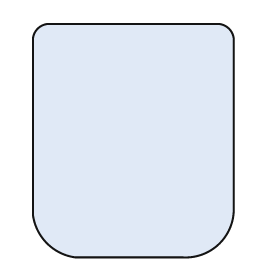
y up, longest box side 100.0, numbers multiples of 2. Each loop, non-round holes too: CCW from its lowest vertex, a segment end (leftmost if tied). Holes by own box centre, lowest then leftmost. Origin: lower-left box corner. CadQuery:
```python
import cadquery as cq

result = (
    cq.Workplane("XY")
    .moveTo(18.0, 0.0)
    .lineTo(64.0, 0.0)
    .threePointArc((80.0, 6.0), (86.0, 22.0))
    .lineTo(86.0, 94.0)
    .threePointArc((84.0, 98.0), (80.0, 100.0))
    .lineTo(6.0, 100.0)
    .threePointArc((2.0, 98.0), (0.0, 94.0))
    .lineTo(0.0, 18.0)
    .threePointArc((6.0, 6.0), (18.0, 0.0))
    .close()
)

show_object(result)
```